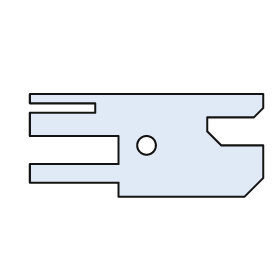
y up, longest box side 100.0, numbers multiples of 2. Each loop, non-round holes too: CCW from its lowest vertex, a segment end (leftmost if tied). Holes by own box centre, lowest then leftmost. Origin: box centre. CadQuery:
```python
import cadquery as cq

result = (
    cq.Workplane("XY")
    .moveTo(-12.0, -22.0)
    .lineTo(42.0, -22.0)
    .lineTo(50.0, -14.0)
    .lineTo(50.0, 0.0)
    .lineTo(32.0, 0.0)
    .lineTo(26.0, 6.0)
    .lineTo(26.0, 12.0)
    .lineTo(46.0, 12.0)
    .lineTo(50.0, 16.0)
    .lineTo(50.0, 22.0)
    .lineTo(-50.0, 22.0)
    .lineTo(-50.0, 18.0)
    .lineTo(-22.0, 18.0)
    .lineTo(-22.0, 14.0)
    .lineTo(-50.0, 14.0)
    .lineTo(-50.0, 4.0)
    .lineTo(-12.0, 4.0)
    .lineTo(-12.0, -8.0)
    .lineTo(-50.0, -8.0)
    .lineTo(-50.0, -16.0)
    .lineTo(-12.0, -16.0)
    .close()
    .moveTo(0.0, 0.0)
    .circle(4.0)
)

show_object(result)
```